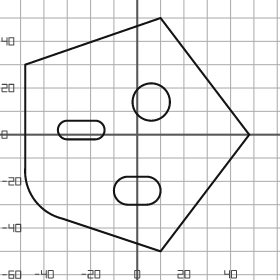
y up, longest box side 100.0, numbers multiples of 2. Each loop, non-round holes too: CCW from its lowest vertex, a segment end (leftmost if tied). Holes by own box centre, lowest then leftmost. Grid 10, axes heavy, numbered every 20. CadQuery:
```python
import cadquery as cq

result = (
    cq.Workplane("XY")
    .moveTo(10.0, -50.0)
    .lineTo(48.0, 0.0)
    .lineTo(10.0, 50.0)
    .lineTo(-48.0, 30.0)
    .lineTo(-48.0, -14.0)
    .threePointArc((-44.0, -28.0), (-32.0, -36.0))
    .close()
    .moveTo(-4.0, -30.0)
    .lineTo(4.0, -30.0)
    .threePointArc((10.0, -24.0), (4.0, -18.0))
    .lineTo(-4.0, -18.0)
    .threePointArc((-10.0, -24.0), (-4.0, -30.0))
    .close()
    .moveTo(-30.0, -2.0)
    .lineTo(-18.0, -2.0)
    .threePointArc((-14.0, 2.0), (-18.0, 6.0))
    .lineTo(-30.0, 6.0)
    .threePointArc((-34.0, 2.0), (-30.0, -2.0))
    .close()
    .moveTo(6.0, 14.0)
    .circle(8.0)
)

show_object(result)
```